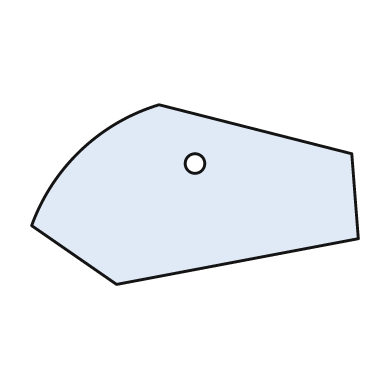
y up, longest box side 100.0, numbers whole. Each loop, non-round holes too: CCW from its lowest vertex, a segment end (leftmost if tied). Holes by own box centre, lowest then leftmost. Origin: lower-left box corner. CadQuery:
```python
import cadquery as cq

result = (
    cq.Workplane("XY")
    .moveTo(26.0, 0.0)
    .lineTo(100.0, 14.0)
    .lineTo(98.0, 40.0)
    .lineTo(39.0, 55.0)
    .threePointArc((15.0, 41.0), (0.0, 18.0))
    .close()
    .moveTo(50.0, 37.0)
    .circle(3.0)
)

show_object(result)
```